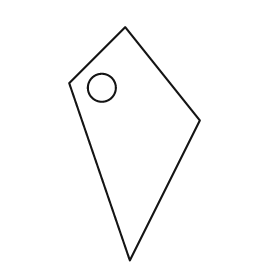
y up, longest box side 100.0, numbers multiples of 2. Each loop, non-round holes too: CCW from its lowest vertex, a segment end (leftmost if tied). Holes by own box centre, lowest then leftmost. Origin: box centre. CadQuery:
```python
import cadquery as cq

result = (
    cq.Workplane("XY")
    .moveTo(-2.0, -50.0)
    .lineTo(28.0, 10.0)
    .lineTo(-4.0, 50.0)
    .lineTo(-28.0, 26.0)
    .close()
    .moveTo(-14.0, 24.0)
    .circle(6.0)
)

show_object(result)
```